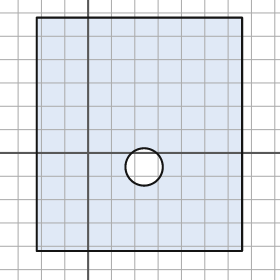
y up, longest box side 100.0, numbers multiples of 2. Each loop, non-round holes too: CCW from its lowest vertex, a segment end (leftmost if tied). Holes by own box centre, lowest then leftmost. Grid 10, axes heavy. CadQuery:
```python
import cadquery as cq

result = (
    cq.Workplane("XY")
    .moveTo(-22.0, -42.0)
    .lineTo(66.0, -42.0)
    .lineTo(66.0, 58.0)
    .lineTo(-22.0, 58.0)
    .close()
    .moveTo(24.0, -6.0)
    .circle(8.0)
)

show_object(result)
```